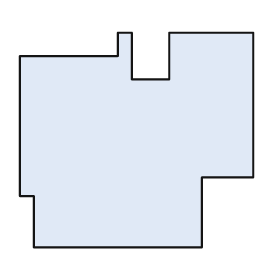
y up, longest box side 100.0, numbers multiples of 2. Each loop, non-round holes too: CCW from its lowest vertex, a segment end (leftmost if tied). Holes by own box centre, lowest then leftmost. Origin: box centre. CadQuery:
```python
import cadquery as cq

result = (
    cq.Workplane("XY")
    .moveTo(-44.0, -46.0)
    .lineTo(28.0, -46.0)
    .lineTo(28.0, -16.0)
    .lineTo(50.0, -16.0)
    .lineTo(50.0, 46.0)
    .lineTo(14.0, 46.0)
    .lineTo(14.0, 26.0)
    .lineTo(-2.0, 26.0)
    .lineTo(-2.0, 46.0)
    .lineTo(-8.0, 46.0)
    .lineTo(-8.0, 36.0)
    .lineTo(-50.0, 36.0)
    .lineTo(-50.0, -24.0)
    .lineTo(-44.0, -24.0)
    .close()
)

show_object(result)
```